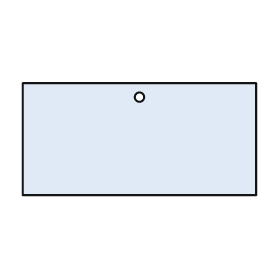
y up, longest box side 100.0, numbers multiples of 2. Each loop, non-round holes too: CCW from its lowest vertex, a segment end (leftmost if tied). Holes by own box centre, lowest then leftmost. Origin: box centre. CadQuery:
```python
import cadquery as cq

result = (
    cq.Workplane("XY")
    .moveTo(-50.0, -24.0)
    .lineTo(50.0, -24.0)
    .lineTo(50.0, 24.0)
    .lineTo(-50.0, 24.0)
    .close()
    .moveTo(0.0, 18.0)
    .circle(2.0)
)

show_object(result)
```